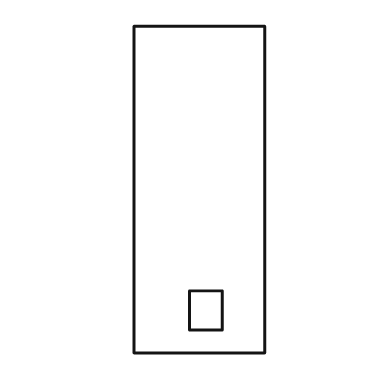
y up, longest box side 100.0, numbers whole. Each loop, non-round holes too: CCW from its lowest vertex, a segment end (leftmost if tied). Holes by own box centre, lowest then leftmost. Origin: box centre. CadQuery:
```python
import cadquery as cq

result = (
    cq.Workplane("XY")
    .moveTo(-20.0, -50.0)
    .lineTo(20.0, -50.0)
    .lineTo(20.0, 50.0)
    .lineTo(-20.0, 50.0)
    .close()
    .moveTo(-3.0, -43.0)
    .lineTo(7.0, -43.0)
    .lineTo(7.0, -31.0)
    .lineTo(-3.0, -31.0)
    .close()
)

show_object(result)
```